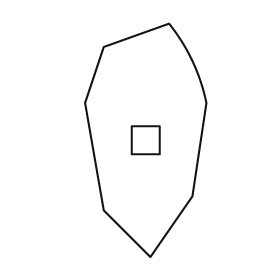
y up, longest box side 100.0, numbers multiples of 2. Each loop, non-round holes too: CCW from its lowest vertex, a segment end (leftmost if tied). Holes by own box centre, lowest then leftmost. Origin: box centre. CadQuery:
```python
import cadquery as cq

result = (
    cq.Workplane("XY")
    .moveTo(2.0, -50.0)
    .lineTo(20.0, -24.0)
    .lineTo(26.0, 16.0)
    .threePointArc((20.0, 34.0), (10.0, 50.0))
    .lineTo(-18.0, 40.0)
    .lineTo(-26.0, 16.0)
    .lineTo(-18.0, -30.0)
    .close()
    .moveTo(-6.0, -6.0)
    .lineTo(6.0, -6.0)
    .lineTo(6.0, 6.0)
    .lineTo(-6.0, 6.0)
    .close()
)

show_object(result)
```